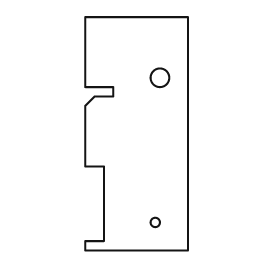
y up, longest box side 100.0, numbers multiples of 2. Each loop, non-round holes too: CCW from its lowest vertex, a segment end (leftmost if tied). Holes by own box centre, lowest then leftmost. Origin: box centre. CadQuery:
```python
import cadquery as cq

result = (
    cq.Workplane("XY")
    .moveTo(-22.0, -50.0)
    .lineTo(22.0, -50.0)
    .lineTo(22.0, 50.0)
    .lineTo(-22.0, 50.0)
    .lineTo(-22.0, 20.0)
    .lineTo(-10.0, 20.0)
    .lineTo(-10.0, 16.0)
    .lineTo(-18.0, 16.0)
    .lineTo(-22.0, 12.0)
    .lineTo(-22.0, -14.0)
    .lineTo(-14.0, -14.0)
    .lineTo(-14.0, -46.0)
    .lineTo(-22.0, -46.0)
    .close()
    .moveTo(8.0, -38.0)
    .circle(2.0)
    .moveTo(10.0, 24.0)
    .circle(4.0)
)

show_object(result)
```